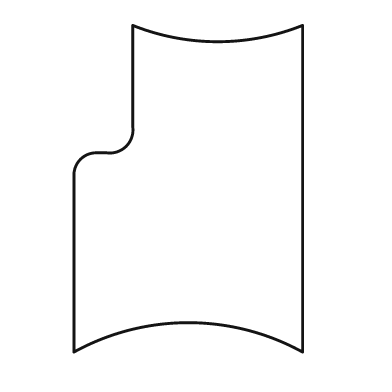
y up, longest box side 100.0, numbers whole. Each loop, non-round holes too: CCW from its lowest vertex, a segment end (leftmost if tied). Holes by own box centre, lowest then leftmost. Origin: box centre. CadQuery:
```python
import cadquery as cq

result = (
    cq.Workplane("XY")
    .moveTo(-35.0, -50.0)
    .threePointArc((0.0, -41.0), (35.0, -50.0))
    .lineTo(35.0, 50.0)
    .threePointArc((9.0, 45.0), (-17.0, 50.0))
    .lineTo(-17.0, 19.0)
    .threePointArc((-19.0, 13.0), (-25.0, 11.0))
    .lineTo(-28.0, 11.0)
    .threePointArc((-33.0, 9.0), (-35.0, 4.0))
    .close()
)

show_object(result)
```